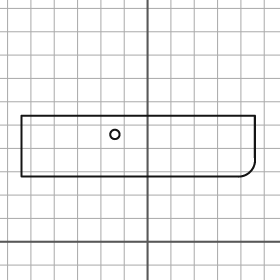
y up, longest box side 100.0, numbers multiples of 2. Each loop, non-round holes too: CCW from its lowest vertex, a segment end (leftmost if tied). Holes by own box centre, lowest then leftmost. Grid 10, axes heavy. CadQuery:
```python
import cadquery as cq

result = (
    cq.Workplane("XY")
    .moveTo(-54.0, 28.0)
    .lineTo(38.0, 28.0)
    .threePointArc((44.0, 30.0), (46.0, 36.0))
    .lineTo(46.0, 54.0)
    .lineTo(-54.0, 54.0)
    .close()
    .moveTo(-14.0, 46.0)
    .circle(2.0)
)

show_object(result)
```